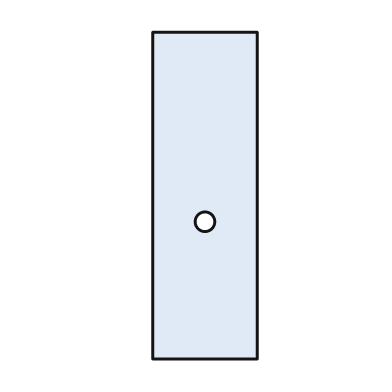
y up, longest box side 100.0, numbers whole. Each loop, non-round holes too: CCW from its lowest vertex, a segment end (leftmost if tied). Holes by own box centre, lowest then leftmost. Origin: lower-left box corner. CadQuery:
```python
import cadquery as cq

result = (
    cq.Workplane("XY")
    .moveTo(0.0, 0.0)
    .lineTo(32.0, 0.0)
    .lineTo(32.0, 100.0)
    .lineTo(0.0, 100.0)
    .close()
    .moveTo(16.0, 42.0)
    .circle(3.0)
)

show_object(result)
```